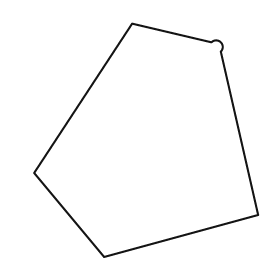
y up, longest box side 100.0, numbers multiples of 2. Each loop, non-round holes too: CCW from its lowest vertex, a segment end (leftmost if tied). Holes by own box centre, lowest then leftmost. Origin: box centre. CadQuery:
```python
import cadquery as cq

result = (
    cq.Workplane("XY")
    .moveTo(-18.0, -50.0)
    .lineTo(48.0, -32.0)
    .lineTo(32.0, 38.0)
    .threePointArc((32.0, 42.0), (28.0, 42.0))
    .lineTo(-6.0, 50.0)
    .lineTo(-48.0, -14.0)
    .close()
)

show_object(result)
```